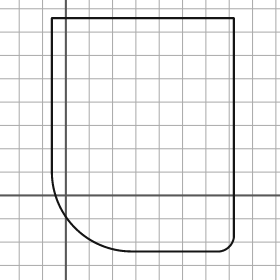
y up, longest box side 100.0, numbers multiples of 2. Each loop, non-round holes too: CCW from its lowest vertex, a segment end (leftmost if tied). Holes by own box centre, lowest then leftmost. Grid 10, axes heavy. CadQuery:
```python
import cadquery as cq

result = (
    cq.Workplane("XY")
    .moveTo(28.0, -24.0)
    .lineTo(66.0, -24.0)
    .threePointArc((70.0, -22.0), (72.0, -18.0))
    .lineTo(72.0, 76.0)
    .lineTo(-6.0, 76.0)
    .lineTo(-6.0, 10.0)
    .threePointArc((4.0, -14.0), (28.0, -24.0))
    .close()
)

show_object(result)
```